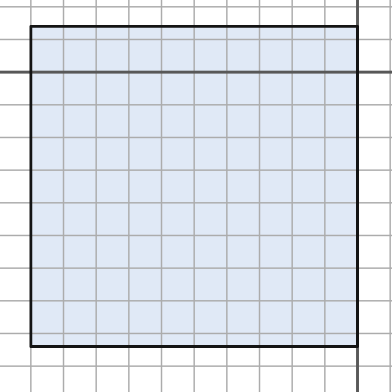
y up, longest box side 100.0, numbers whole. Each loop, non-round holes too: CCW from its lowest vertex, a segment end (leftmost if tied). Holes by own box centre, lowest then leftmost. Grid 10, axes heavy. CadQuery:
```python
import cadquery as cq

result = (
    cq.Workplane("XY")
    .moveTo(-100.0, -84.0)
    .lineTo(0.0, -84.0)
    .lineTo(0.0, 14.0)
    .lineTo(-100.0, 14.0)
    .close()
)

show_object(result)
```